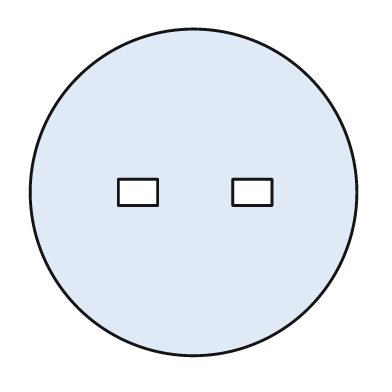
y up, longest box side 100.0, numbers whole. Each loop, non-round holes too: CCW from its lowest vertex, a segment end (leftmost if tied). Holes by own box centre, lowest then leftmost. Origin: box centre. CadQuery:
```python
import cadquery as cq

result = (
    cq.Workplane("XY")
    .moveTo(0.0, 0.0)
    .circle(50.0)
    .moveTo(-23.0, -4.0)
    .lineTo(-11.0, -4.0)
    .lineTo(-11.0, 4.0)
    .lineTo(-23.0, 4.0)
    .close()
    .moveTo(12.0, -4.0)
    .lineTo(24.0, -4.0)
    .lineTo(24.0, 4.0)
    .lineTo(12.0, 4.0)
    .close()
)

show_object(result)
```